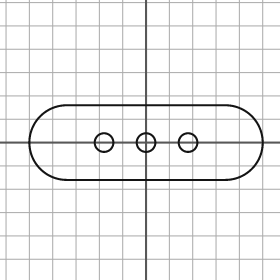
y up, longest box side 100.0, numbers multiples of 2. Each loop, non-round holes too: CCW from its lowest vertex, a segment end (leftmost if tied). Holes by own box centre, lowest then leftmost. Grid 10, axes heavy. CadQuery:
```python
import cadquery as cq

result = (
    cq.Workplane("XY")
    .moveTo(-34.0, -16.0)
    .lineTo(34.0, -16.0)
    .threePointArc((50.0, 0.0), (34.0, 16.0))
    .lineTo(-34.0, 16.0)
    .threePointArc((-50.0, 0.0), (-34.0, -16.0))
    .close()
    .moveTo(-18.0, 0.0)
    .circle(4.0)
    .moveTo(0.0, 0.0)
    .circle(4.0)
    .moveTo(18.0, 0.0)
    .circle(4.0)
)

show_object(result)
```